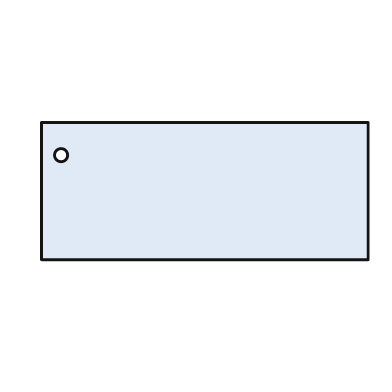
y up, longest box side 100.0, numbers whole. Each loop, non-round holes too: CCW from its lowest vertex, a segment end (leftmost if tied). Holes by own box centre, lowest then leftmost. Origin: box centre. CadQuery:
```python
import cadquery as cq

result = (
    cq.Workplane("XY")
    .moveTo(-50.0, -21.0)
    .lineTo(50.0, -21.0)
    .lineTo(50.0, 21.0)
    .lineTo(-50.0, 21.0)
    .close()
    .moveTo(-44.0, 11.0)
    .circle(2.0)
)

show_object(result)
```